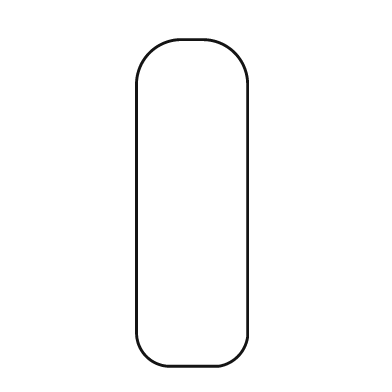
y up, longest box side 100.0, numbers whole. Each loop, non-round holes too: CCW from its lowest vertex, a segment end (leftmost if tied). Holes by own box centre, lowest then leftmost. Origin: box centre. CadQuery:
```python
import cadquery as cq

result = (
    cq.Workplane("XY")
    .moveTo(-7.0, -50.0)
    .lineTo(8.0, -50.0)
    .threePointArc((14.0, -47.0), (17.0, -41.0))
    .lineTo(17.0, 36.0)
    .threePointArc((13.0, 46.0), (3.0, 50.0))
    .lineTo(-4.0, 50.0)
    .threePointArc((-13.0, 46.0), (-17.0, 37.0))
    .lineTo(-17.0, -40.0)
    .threePointArc((-14.0, -47.0), (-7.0, -50.0))
    .close()
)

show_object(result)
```